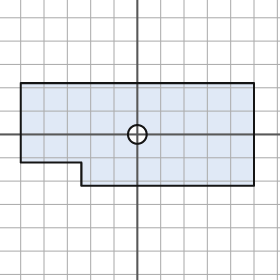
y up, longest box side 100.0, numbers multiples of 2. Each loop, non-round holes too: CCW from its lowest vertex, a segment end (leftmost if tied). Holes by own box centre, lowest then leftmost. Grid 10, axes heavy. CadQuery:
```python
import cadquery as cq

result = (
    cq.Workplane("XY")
    .moveTo(-24.0, -22.0)
    .lineTo(50.0, -22.0)
    .lineTo(50.0, 22.0)
    .lineTo(-50.0, 22.0)
    .lineTo(-50.0, -12.0)
    .lineTo(-24.0, -12.0)
    .close()
    .moveTo(0.0, 0.0)
    .circle(4.0)
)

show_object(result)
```